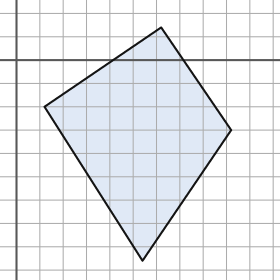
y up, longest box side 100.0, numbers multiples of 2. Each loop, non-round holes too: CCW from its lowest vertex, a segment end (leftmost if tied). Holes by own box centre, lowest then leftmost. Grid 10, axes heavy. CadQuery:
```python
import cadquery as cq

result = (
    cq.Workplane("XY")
    .moveTo(54.0, -86.0)
    .lineTo(92.0, -30.0)
    .lineTo(62.0, 14.0)
    .lineTo(12.0, -20.0)
    .close()
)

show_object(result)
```